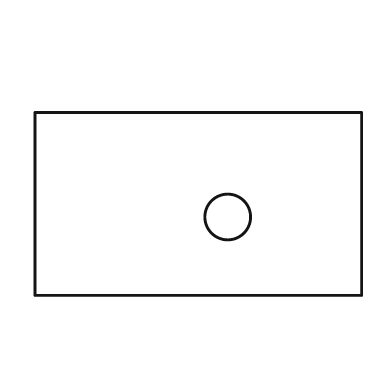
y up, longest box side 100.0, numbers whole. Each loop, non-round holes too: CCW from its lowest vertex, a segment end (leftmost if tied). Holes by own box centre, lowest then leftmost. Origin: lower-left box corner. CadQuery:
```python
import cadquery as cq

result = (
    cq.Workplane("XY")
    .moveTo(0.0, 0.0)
    .lineTo(100.0, 0.0)
    .lineTo(100.0, 56.0)
    .lineTo(0.0, 56.0)
    .close()
    .moveTo(59.0, 24.0)
    .circle(7.0)
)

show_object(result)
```